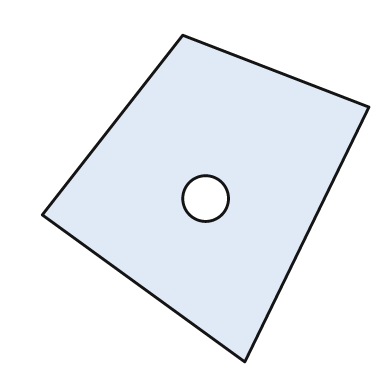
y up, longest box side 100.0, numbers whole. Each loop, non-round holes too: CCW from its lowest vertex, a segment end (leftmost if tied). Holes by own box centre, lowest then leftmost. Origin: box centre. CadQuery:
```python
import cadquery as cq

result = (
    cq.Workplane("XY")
    .moveTo(12.0, -50.0)
    .lineTo(50.0, 28.0)
    .lineTo(-7.0, 50.0)
    .lineTo(-50.0, -5.0)
    .close()
    .moveTo(0.0, 0.0)
    .circle(7.0)
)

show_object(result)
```